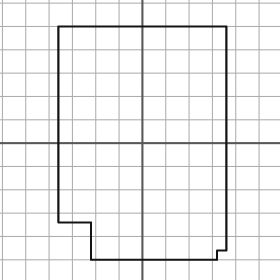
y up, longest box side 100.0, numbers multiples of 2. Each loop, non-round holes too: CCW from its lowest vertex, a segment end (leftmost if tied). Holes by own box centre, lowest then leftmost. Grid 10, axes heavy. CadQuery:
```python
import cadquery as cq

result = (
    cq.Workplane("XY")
    .moveTo(-22.0, -50.0)
    .lineTo(32.0, -50.0)
    .lineTo(32.0, -46.0)
    .lineTo(36.0, -46.0)
    .lineTo(36.0, 50.0)
    .lineTo(-36.0, 50.0)
    .lineTo(-36.0, -34.0)
    .lineTo(-22.0, -34.0)
    .close()
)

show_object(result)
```